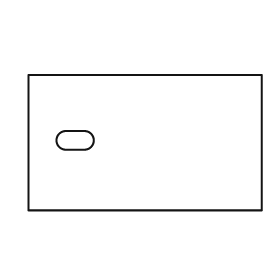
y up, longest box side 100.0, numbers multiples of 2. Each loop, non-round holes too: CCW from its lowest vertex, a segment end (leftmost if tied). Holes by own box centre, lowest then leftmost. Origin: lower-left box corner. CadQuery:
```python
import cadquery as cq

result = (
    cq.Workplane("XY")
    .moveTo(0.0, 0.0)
    .lineTo(100.0, 0.0)
    .lineTo(100.0, 58.0)
    .lineTo(0.0, 58.0)
    .close()
    .moveTo(16.0, 26.0)
    .lineTo(24.0, 26.0)
    .threePointArc((28.0, 30.0), (24.0, 34.0))
    .lineTo(16.0, 34.0)
    .threePointArc((12.0, 30.0), (16.0, 26.0))
    .close()
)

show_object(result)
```